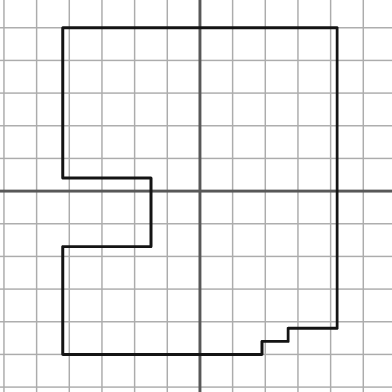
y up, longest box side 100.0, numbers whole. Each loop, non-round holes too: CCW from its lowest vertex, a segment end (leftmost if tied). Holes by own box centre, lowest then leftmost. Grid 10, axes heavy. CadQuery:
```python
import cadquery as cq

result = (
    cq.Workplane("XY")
    .moveTo(-42.0, -50.0)
    .lineTo(19.0, -50.0)
    .lineTo(19.0, -46.0)
    .lineTo(27.0, -46.0)
    .lineTo(27.0, -42.0)
    .lineTo(42.0, -42.0)
    .lineTo(42.0, 50.0)
    .lineTo(-42.0, 50.0)
    .lineTo(-42.0, 4.0)
    .lineTo(-15.0, 4.0)
    .lineTo(-15.0, -17.0)
    .lineTo(-42.0, -17.0)
    .close()
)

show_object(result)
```